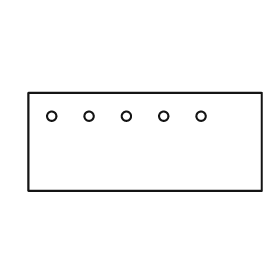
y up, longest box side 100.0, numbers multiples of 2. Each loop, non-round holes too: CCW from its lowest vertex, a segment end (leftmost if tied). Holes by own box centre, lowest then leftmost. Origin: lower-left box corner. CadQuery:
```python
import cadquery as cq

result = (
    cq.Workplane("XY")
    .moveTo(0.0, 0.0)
    .lineTo(100.0, 0.0)
    .lineTo(100.0, 42.0)
    .lineTo(0.0, 42.0)
    .close()
    .moveTo(10.0, 32.0)
    .circle(2.0)
    .moveTo(26.0, 32.0)
    .circle(2.0)
    .moveTo(42.0, 32.0)
    .circle(2.0)
    .moveTo(58.0, 32.0)
    .circle(2.0)
    .moveTo(74.0, 32.0)
    .circle(2.0)
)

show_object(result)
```